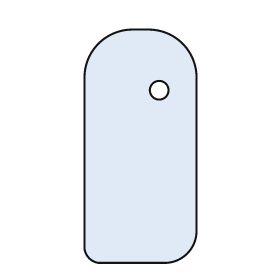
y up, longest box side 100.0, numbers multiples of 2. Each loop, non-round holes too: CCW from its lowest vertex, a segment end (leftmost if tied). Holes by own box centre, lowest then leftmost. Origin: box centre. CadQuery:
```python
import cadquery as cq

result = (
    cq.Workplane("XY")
    .moveTo(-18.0, -50.0)
    .lineTo(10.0, -50.0)
    .threePointArc((20.0, -46.0), (24.0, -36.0))
    .lineTo(24.0, 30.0)
    .threePointArc((18.0, 44.0), (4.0, 50.0))
    .lineTo(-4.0, 50.0)
    .threePointArc((-18.0, 44.0), (-24.0, 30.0))
    .lineTo(-24.0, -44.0)
    .threePointArc((-22.0, -48.0), (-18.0, -50.0))
    .close()
    .moveTo(8.0, 24.0)
    .circle(4.0)
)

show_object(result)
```